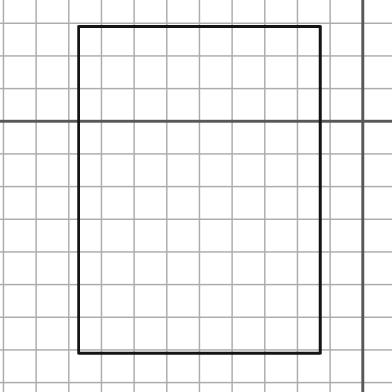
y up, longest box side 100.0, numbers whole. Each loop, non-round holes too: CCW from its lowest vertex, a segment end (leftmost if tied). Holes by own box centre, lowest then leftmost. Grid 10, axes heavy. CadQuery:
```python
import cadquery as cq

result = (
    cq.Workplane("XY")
    .moveTo(-87.0, -71.0)
    .lineTo(-13.0, -71.0)
    .lineTo(-13.0, 29.0)
    .lineTo(-87.0, 29.0)
    .close()
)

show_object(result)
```